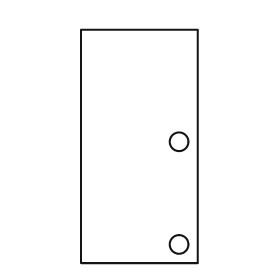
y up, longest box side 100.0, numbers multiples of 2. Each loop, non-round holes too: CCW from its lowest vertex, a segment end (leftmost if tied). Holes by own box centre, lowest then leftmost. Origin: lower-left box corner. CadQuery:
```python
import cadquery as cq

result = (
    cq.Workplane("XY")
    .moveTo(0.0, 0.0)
    .lineTo(50.0, 0.0)
    .lineTo(50.0, 100.0)
    .lineTo(0.0, 100.0)
    .close()
    .moveTo(42.0, 8.0)
    .circle(4.0)
    .moveTo(42.0, 52.0)
    .circle(4.0)
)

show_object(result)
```